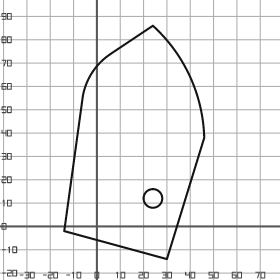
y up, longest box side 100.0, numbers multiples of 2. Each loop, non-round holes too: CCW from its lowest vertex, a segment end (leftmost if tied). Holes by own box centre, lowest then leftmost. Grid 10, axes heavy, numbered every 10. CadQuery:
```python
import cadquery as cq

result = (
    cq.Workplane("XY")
    .moveTo(30.0, -14.0)
    .lineTo(46.0, 38.0)
    .threePointArc((40.0, 64.0), (24.0, 86.0))
    .lineTo(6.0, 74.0)
    .threePointArc((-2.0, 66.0), (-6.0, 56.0))
    .lineTo(-14.0, -2.0)
    .close()
    .moveTo(24.0, 12.0)
    .circle(4.0)
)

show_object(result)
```